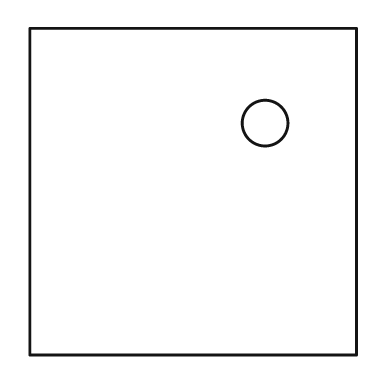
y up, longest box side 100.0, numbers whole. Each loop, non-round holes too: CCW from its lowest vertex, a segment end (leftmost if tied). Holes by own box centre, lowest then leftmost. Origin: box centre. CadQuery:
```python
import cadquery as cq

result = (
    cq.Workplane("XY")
    .moveTo(-50.0, -50.0)
    .lineTo(50.0, -50.0)
    .lineTo(50.0, 50.0)
    .lineTo(-50.0, 50.0)
    .close()
    .moveTo(22.0, 21.0)
    .circle(7.0)
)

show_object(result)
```